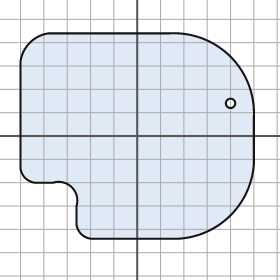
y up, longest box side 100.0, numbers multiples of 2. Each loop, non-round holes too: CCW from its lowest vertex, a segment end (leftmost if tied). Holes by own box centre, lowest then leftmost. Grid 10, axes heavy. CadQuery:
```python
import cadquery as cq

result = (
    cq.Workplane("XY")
    .moveTo(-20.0, -44.0)
    .lineTo(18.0, -44.0)
    .threePointArc((40.0, -34.0), (50.0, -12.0))
    .lineTo(50.0, 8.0)
    .threePointArc((40.0, 34.0), (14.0, 44.0))
    .lineTo(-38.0, 44.0)
    .threePointArc((-46.0, 40.0), (-50.0, 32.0))
    .lineTo(-50.0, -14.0)
    .threePointArc((-48.0, -18.0), (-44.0, -20.0))
    .lineTo(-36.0, -20.0)
    .threePointArc((-28.0, -22.0), (-26.0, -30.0))
    .lineTo(-26.0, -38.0)
    .threePointArc((-24.0, -42.0), (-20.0, -44.0))
    .close()
    .moveTo(40.0, 14.0)
    .circle(2.0)
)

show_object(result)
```